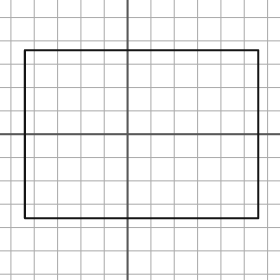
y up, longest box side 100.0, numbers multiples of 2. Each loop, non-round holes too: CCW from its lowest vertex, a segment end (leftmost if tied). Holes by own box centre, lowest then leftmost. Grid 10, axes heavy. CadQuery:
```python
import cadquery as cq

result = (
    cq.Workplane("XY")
    .moveTo(-44.0, -36.0)
    .lineTo(56.0, -36.0)
    .lineTo(56.0, 36.0)
    .lineTo(-44.0, 36.0)
    .close()
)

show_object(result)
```